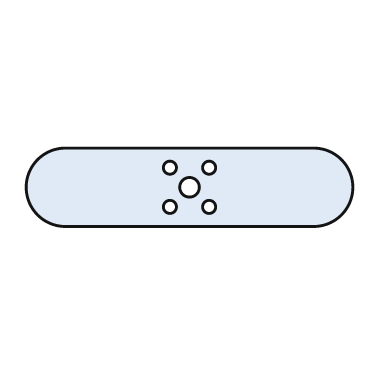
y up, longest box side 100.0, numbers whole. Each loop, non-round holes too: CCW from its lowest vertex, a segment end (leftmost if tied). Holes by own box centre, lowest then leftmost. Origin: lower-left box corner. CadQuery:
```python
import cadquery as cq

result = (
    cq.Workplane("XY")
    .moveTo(12.0, 0.0)
    .lineTo(88.0, 0.0)
    .threePointArc((100.0, 12.0), (88.0, 24.0))
    .lineTo(12.0, 24.0)
    .threePointArc((0.0, 12.0), (12.0, 0.0))
    .close()
    .moveTo(44.0, 6.0)
    .circle(2.0)
    .moveTo(56.0, 6.0)
    .circle(2.0)
    .moveTo(50.0, 12.0)
    .circle(3.0)
    .moveTo(44.0, 18.0)
    .circle(2.0)
    .moveTo(56.0, 18.0)
    .circle(2.0)
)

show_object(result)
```